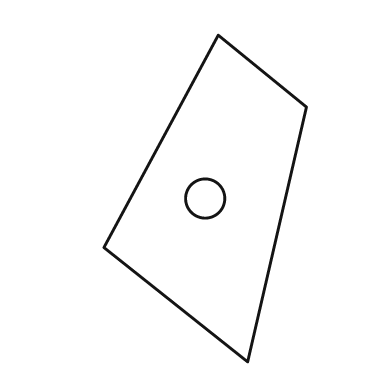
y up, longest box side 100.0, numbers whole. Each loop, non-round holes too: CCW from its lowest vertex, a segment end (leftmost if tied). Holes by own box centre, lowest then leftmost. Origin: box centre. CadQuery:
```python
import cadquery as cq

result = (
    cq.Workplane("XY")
    .moveTo(13.0, -50.0)
    .lineTo(31.0, 28.0)
    .lineTo(4.0, 50.0)
    .lineTo(-31.0, -15.0)
    .close()
    .moveTo(0.0, 0.0)
    .circle(6.0)
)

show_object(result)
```